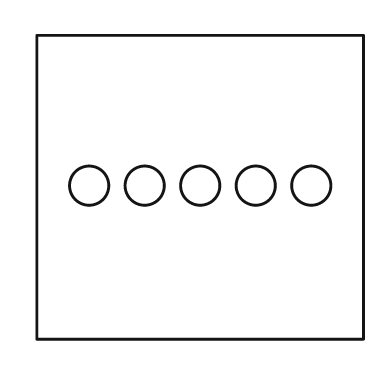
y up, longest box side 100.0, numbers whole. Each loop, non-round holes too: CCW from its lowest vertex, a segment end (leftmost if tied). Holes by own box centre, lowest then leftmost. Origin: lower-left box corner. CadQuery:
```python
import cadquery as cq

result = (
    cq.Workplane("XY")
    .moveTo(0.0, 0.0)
    .lineTo(100.0, 0.0)
    .lineTo(100.0, 93.0)
    .lineTo(0.0, 93.0)
    .close()
    .moveTo(16.0, 47.0)
    .circle(6.0)
    .moveTo(33.0, 47.0)
    .circle(6.0)
    .moveTo(50.0, 47.0)
    .circle(6.0)
    .moveTo(67.0, 47.0)
    .circle(6.0)
    .moveTo(84.0, 47.0)
    .circle(6.0)
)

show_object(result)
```